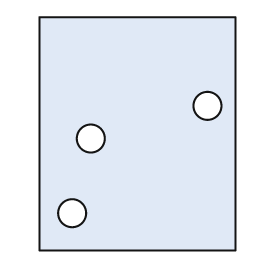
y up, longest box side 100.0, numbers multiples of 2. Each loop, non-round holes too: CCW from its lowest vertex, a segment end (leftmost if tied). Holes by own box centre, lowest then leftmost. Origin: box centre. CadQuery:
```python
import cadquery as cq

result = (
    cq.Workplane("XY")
    .moveTo(-42.0, -50.0)
    .lineTo(42.0, -50.0)
    .lineTo(42.0, 50.0)
    .lineTo(-42.0, 50.0)
    .close()
    .moveTo(-28.0, -34.0)
    .circle(6.0)
    .moveTo(-20.0, -2.0)
    .circle(6.0)
    .moveTo(30.0, 12.0)
    .circle(6.0)
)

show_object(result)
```